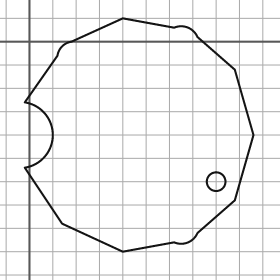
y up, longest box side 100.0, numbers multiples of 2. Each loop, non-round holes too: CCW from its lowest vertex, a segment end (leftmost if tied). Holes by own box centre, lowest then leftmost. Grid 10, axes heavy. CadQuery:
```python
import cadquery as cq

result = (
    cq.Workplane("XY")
    .moveTo(40.0, -90.0)
    .lineTo(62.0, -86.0)
    .threePointArc((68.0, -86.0), (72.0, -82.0))
    .lineTo(88.0, -68.0)
    .lineTo(96.0, -40.0)
    .lineTo(88.0, -12.0)
    .lineTo(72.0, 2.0)
    .threePointArc((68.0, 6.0), (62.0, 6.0))
    .lineTo(40.0, 10.0)
    .lineTo(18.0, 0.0)
    .threePointArc((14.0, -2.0), (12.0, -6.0))
    .lineTo(-2.0, -26.0)
    .threePointArc((10.0, -40.0), (-2.0, -54.0))
    .lineTo(14.0, -78.0)
    .close()
    .moveTo(80.0, -60.0)
    .circle(4.0)
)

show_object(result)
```